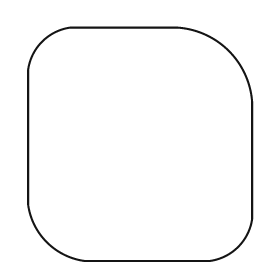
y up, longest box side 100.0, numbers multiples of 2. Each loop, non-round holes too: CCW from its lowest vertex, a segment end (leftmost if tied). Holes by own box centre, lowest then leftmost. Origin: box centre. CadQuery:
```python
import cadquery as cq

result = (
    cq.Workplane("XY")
    .moveTo(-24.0, -50.0)
    .lineTo(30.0, -50.0)
    .threePointArc((42.0, -44.0), (48.0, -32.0))
    .lineTo(48.0, 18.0)
    .threePointArc((38.0, 40.0), (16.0, 50.0))
    .lineTo(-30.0, 50.0)
    .threePointArc((-42.0, 44.0), (-48.0, 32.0))
    .lineTo(-48.0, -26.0)
    .threePointArc((-40.0, -42.0), (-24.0, -50.0))
    .close()
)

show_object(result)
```